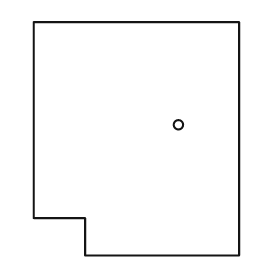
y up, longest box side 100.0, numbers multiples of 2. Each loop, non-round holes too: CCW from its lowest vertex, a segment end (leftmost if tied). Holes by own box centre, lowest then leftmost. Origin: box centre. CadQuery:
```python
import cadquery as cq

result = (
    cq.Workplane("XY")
    .moveTo(-22.0, -50.0)
    .lineTo(44.0, -50.0)
    .lineTo(44.0, 50.0)
    .lineTo(-44.0, 50.0)
    .lineTo(-44.0, -34.0)
    .lineTo(-22.0, -34.0)
    .close()
    .moveTo(18.0, 6.0)
    .circle(2.0)
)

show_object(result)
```